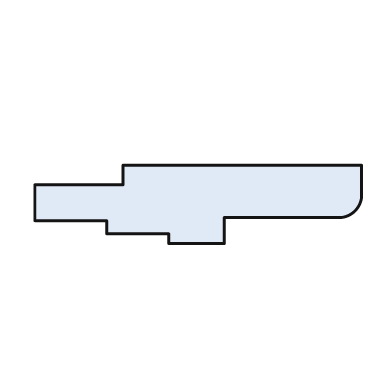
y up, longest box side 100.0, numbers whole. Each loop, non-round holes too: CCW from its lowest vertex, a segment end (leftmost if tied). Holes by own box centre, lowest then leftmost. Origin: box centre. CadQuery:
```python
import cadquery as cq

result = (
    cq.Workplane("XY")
    .moveTo(-9.0, -12.0)
    .lineTo(8.0, -12.0)
    .lineTo(8.0, -4.0)
    .lineTo(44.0, -4.0)
    .threePointArc((48.0, -2.0), (50.0, 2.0))
    .lineTo(50.0, 12.0)
    .lineTo(-23.0, 12.0)
    .lineTo(-23.0, 6.0)
    .lineTo(-50.0, 6.0)
    .lineTo(-50.0, -5.0)
    .lineTo(-28.0, -5.0)
    .lineTo(-28.0, -9.0)
    .lineTo(-9.0, -9.0)
    .close()
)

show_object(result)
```